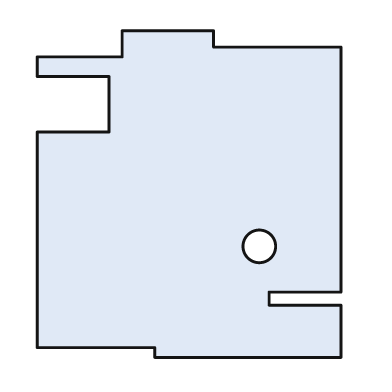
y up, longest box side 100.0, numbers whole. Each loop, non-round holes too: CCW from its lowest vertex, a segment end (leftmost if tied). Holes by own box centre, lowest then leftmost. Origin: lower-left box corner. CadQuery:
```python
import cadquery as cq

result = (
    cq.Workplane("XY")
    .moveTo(36.0, 0.0)
    .lineTo(93.0, 0.0)
    .lineTo(93.0, 16.0)
    .lineTo(71.0, 16.0)
    .lineTo(71.0, 20.0)
    .lineTo(93.0, 20.0)
    .lineTo(93.0, 95.0)
    .lineTo(54.0, 95.0)
    .lineTo(54.0, 100.0)
    .lineTo(26.0, 100.0)
    .lineTo(26.0, 92.0)
    .lineTo(0.0, 92.0)
    .lineTo(0.0, 86.0)
    .lineTo(22.0, 86.0)
    .lineTo(22.0, 69.0)
    .lineTo(0.0, 69.0)
    .lineTo(0.0, 3.0)
    .lineTo(36.0, 3.0)
    .close()
    .moveTo(68.0, 34.0)
    .circle(5.0)
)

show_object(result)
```